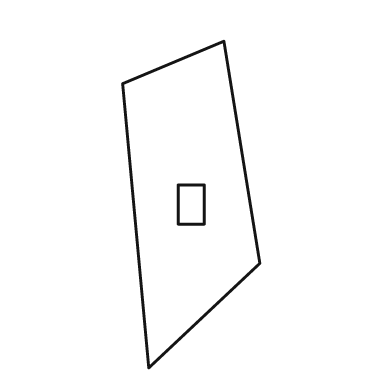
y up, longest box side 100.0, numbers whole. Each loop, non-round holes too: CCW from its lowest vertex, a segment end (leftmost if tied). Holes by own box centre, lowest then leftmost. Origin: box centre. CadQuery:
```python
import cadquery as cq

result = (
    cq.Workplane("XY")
    .moveTo(-13.0, -50.0)
    .lineTo(21.0, -18.0)
    .lineTo(10.0, 50.0)
    .lineTo(-21.0, 37.0)
    .close()
    .moveTo(-4.0, -6.0)
    .lineTo(4.0, -6.0)
    .lineTo(4.0, 6.0)
    .lineTo(-4.0, 6.0)
    .close()
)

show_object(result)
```